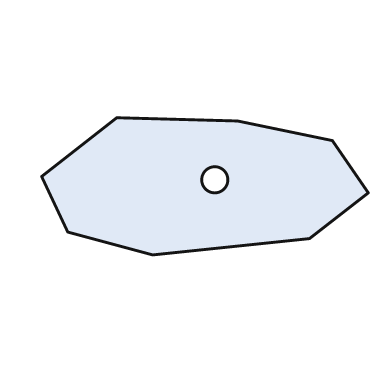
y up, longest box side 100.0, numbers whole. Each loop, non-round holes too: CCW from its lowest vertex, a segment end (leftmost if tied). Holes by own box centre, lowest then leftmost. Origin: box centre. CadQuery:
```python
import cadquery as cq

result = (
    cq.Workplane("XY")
    .moveTo(-16.0, -21.0)
    .lineTo(32.0, -16.0)
    .lineTo(50.0, -2.0)
    .lineTo(39.0, 14.0)
    .lineTo(10.0, 20.0)
    .lineTo(-27.0, 21.0)
    .lineTo(-50.0, 3.0)
    .lineTo(-42.0, -14.0)
    .close()
    .moveTo(3.0, 2.0)
    .circle(4.0)
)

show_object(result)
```